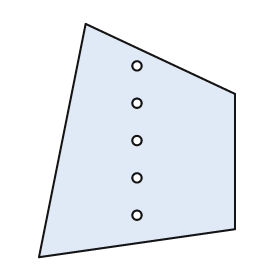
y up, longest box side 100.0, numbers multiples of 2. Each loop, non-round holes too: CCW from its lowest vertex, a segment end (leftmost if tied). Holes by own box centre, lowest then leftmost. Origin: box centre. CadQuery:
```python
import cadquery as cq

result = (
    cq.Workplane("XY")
    .moveTo(-42.0, -50.0)
    .lineTo(42.0, -38.0)
    .lineTo(42.0, 20.0)
    .lineTo(-22.0, 50.0)
    .close()
    .moveTo(0.0, -32.0)
    .circle(2.0)
    .moveTo(0.0, -16.0)
    .circle(2.0)
    .moveTo(0.0, 0.0)
    .circle(2.0)
    .moveTo(0.0, 16.0)
    .circle(2.0)
    .moveTo(0.0, 32.0)
    .circle(2.0)
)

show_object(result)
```